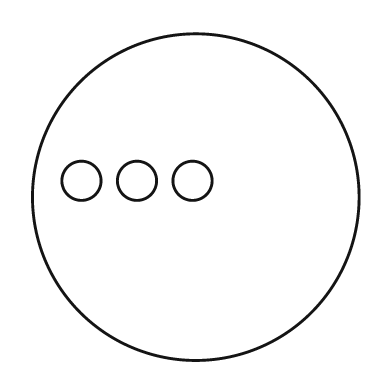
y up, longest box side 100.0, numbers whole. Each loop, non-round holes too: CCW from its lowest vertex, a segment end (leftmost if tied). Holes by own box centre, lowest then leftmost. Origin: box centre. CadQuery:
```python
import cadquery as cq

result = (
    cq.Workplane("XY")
    .moveTo(0.0, 0.0)
    .circle(50.0)
    .moveTo(-35.0, 5.0)
    .circle(6.0)
    .moveTo(-18.0, 5.0)
    .circle(6.0)
    .moveTo(-1.0, 5.0)
    .circle(6.0)
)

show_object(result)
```